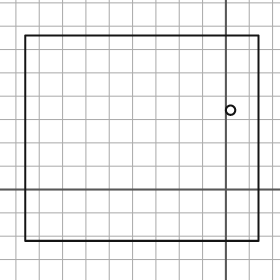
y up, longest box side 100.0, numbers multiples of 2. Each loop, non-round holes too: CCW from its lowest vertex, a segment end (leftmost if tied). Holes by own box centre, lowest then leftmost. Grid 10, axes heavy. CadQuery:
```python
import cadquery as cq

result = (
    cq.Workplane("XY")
    .moveTo(-86.0, -22.0)
    .lineTo(14.0, -22.0)
    .lineTo(14.0, 66.0)
    .lineTo(-86.0, 66.0)
    .close()
    .moveTo(2.0, 34.0)
    .circle(2.0)
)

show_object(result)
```